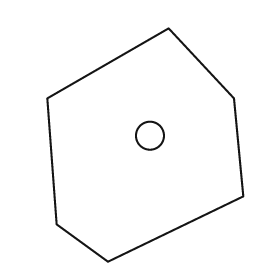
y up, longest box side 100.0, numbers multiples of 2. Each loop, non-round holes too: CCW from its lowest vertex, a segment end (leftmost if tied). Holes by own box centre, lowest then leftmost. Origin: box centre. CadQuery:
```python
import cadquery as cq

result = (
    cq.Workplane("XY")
    .moveTo(-16.0, -50.0)
    .lineTo(42.0, -22.0)
    .lineTo(38.0, 20.0)
    .lineTo(10.0, 50.0)
    .lineTo(-42.0, 20.0)
    .lineTo(-38.0, -34.0)
    .close()
    .moveTo(2.0, 4.0)
    .circle(6.0)
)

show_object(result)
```